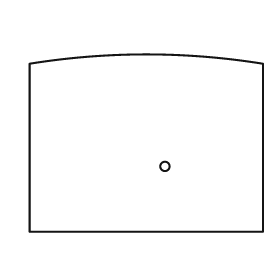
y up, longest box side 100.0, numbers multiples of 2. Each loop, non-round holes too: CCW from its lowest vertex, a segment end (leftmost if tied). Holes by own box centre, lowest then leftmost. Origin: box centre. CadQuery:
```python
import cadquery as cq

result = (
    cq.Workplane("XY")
    .moveTo(-50.0, -38.0)
    .lineTo(50.0, -38.0)
    .lineTo(50.0, 34.0)
    .threePointArc((0.0, 38.0), (-50.0, 34.0))
    .close()
    .moveTo(8.0, -10.0)
    .circle(2.0)
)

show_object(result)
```